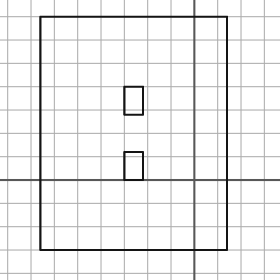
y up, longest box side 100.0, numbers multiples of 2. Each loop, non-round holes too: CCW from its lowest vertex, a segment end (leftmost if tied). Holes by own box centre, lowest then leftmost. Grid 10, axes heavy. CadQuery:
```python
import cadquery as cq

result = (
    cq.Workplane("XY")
    .moveTo(-66.0, -30.0)
    .lineTo(14.0, -30.0)
    .lineTo(14.0, 70.0)
    .lineTo(-66.0, 70.0)
    .close()
    .moveTo(-30.0, 0.0)
    .lineTo(-22.0, 0.0)
    .lineTo(-22.0, 12.0)
    .lineTo(-30.0, 12.0)
    .close()
    .moveTo(-30.0, 28.0)
    .lineTo(-22.0, 28.0)
    .lineTo(-22.0, 40.0)
    .lineTo(-30.0, 40.0)
    .close()
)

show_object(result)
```